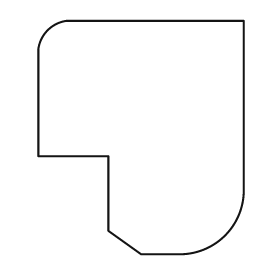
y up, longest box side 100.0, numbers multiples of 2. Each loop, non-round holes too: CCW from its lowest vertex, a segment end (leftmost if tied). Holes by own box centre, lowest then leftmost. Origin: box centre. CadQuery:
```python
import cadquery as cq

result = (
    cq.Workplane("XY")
    .moveTo(0.0, -50.0)
    .lineTo(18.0, -50.0)
    .threePointArc((36.0, -42.0), (44.0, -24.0))
    .lineTo(44.0, 50.0)
    .lineTo(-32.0, 50.0)
    .threePointArc((-40.0, 46.0), (-44.0, 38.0))
    .lineTo(-44.0, -8.0)
    .lineTo(-14.0, -8.0)
    .lineTo(-14.0, -40.0)
    .close()
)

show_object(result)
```